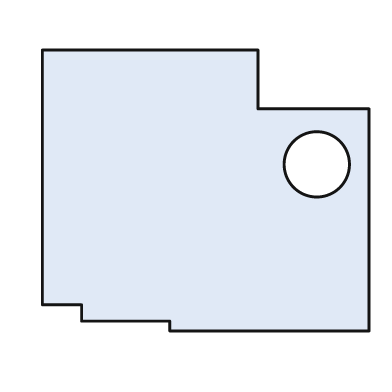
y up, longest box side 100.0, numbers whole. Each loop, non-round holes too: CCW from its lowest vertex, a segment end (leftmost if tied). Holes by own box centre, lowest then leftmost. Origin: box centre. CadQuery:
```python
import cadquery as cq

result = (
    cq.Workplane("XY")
    .moveTo(-11.0, -43.0)
    .lineTo(50.0, -43.0)
    .lineTo(50.0, 25.0)
    .lineTo(16.0, 25.0)
    .lineTo(16.0, 43.0)
    .lineTo(-50.0, 43.0)
    .lineTo(-50.0, -35.0)
    .lineTo(-38.0, -35.0)
    .lineTo(-38.0, -40.0)
    .lineTo(-11.0, -40.0)
    .close()
    .moveTo(34.0, 8.0)
    .circle(10.0)
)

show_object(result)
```